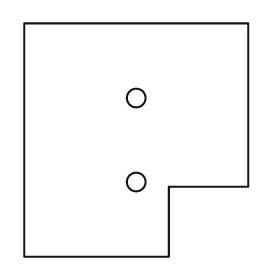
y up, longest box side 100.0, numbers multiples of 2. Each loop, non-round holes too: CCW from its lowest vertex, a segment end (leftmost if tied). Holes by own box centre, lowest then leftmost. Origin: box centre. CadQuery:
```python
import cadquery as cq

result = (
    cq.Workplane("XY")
    .moveTo(-48.0, -50.0)
    .lineTo(14.0, -50.0)
    .lineTo(14.0, -20.0)
    .lineTo(48.0, -20.0)
    .lineTo(48.0, 50.0)
    .lineTo(-48.0, 50.0)
    .close()
    .moveTo(0.0, -18.0)
    .circle(4.0)
    .moveTo(0.0, 18.0)
    .circle(4.0)
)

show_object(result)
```